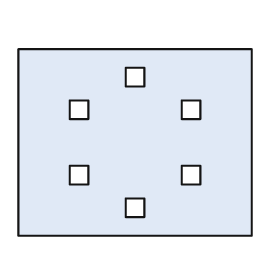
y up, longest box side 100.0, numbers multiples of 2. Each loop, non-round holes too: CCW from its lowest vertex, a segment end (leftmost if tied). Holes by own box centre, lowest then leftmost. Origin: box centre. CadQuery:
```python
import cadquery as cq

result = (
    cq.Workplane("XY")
    .moveTo(-50.0, -40.0)
    .lineTo(50.0, -40.0)
    .lineTo(50.0, 40.0)
    .lineTo(-50.0, 40.0)
    .close()
    .moveTo(-4.0, -32.0)
    .lineTo(4.0, -32.0)
    .lineTo(4.0, -24.0)
    .lineTo(-4.0, -24.0)
    .close()
    .moveTo(-28.0, -18.0)
    .lineTo(-20.0, -18.0)
    .lineTo(-20.0, -10.0)
    .lineTo(-28.0, -10.0)
    .close()
    .moveTo(20.0, -18.0)
    .lineTo(28.0, -18.0)
    .lineTo(28.0, -10.0)
    .lineTo(20.0, -10.0)
    .close()
    .moveTo(-28.0, 10.0)
    .lineTo(-20.0, 10.0)
    .lineTo(-20.0, 18.0)
    .lineTo(-28.0, 18.0)
    .close()
    .moveTo(20.0, 10.0)
    .lineTo(28.0, 10.0)
    .lineTo(28.0, 18.0)
    .lineTo(20.0, 18.0)
    .close()
    .moveTo(-4.0, 24.0)
    .lineTo(4.0, 24.0)
    .lineTo(4.0, 32.0)
    .lineTo(-4.0, 32.0)
    .close()
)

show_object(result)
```